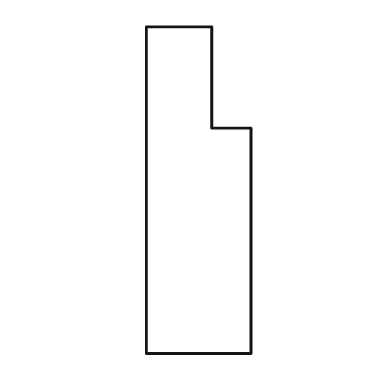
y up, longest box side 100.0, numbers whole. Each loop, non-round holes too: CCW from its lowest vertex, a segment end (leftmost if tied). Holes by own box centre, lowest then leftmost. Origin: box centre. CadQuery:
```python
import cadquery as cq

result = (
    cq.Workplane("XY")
    .moveTo(-16.0, -50.0)
    .lineTo(16.0, -50.0)
    .lineTo(16.0, 19.0)
    .lineTo(4.0, 19.0)
    .lineTo(4.0, 50.0)
    .lineTo(-16.0, 50.0)
    .close()
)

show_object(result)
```